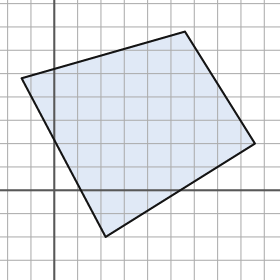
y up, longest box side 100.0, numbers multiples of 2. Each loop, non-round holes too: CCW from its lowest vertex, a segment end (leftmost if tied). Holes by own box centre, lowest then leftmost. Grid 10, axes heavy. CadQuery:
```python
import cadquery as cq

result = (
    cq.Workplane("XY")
    .moveTo(22.0, -20.0)
    .lineTo(86.0, 20.0)
    .lineTo(56.0, 68.0)
    .lineTo(-14.0, 48.0)
    .close()
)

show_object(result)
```